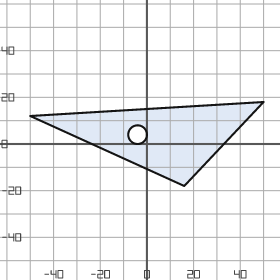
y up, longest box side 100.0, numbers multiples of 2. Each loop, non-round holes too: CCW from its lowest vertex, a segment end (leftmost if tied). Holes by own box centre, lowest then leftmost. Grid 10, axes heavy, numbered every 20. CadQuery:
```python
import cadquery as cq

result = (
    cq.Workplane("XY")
    .moveTo(16.0, -18.0)
    .lineTo(50.0, 18.0)
    .lineTo(-50.0, 12.0)
    .close()
    .moveTo(-4.0, 4.0)
    .circle(4.0)
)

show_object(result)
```